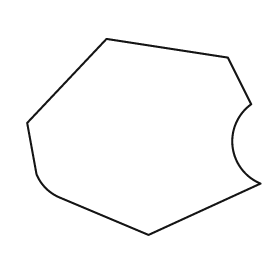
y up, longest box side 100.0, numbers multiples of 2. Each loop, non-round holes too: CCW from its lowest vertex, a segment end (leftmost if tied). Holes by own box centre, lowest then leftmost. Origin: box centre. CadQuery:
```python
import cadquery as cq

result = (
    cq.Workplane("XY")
    .moveTo(2.0, -42.0)
    .lineTo(50.0, -20.0)
    .threePointArc((38.0, -4.0), (46.0, 14.0))
    .lineTo(36.0, 34.0)
    .lineTo(-16.0, 42.0)
    .lineTo(-50.0, 6.0)
    .lineTo(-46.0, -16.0)
    .threePointArc((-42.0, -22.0), (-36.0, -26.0))
    .close()
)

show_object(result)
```